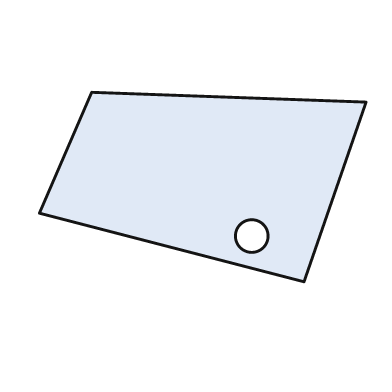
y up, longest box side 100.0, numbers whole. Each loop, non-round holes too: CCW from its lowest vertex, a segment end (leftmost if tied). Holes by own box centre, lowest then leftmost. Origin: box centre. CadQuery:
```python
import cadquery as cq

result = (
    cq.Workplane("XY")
    .moveTo(31.0, -29.0)
    .lineTo(50.0, 26.0)
    .lineTo(-34.0, 29.0)
    .lineTo(-50.0, -8.0)
    .close()
    .moveTo(15.0, -15.0)
    .circle(5.0)
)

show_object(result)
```